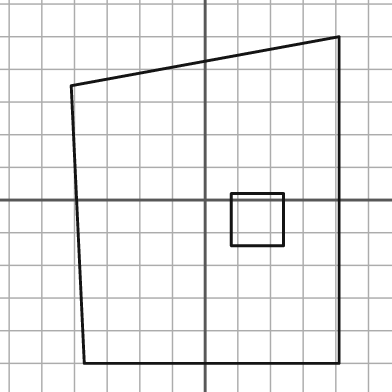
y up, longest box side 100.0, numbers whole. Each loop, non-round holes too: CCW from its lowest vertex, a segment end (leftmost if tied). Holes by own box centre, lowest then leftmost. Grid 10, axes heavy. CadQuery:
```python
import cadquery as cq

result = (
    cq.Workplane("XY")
    .moveTo(-37.0, -50.0)
    .lineTo(41.0, -50.0)
    .lineTo(41.0, 50.0)
    .lineTo(-41.0, 35.0)
    .close()
    .moveTo(8.0, -14.0)
    .lineTo(24.0, -14.0)
    .lineTo(24.0, 2.0)
    .lineTo(8.0, 2.0)
    .close()
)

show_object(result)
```